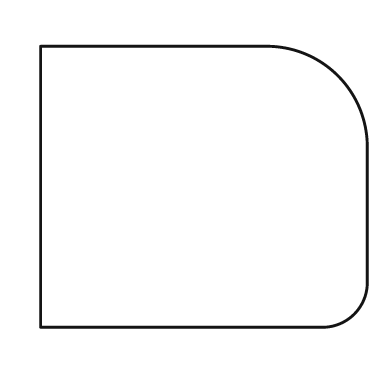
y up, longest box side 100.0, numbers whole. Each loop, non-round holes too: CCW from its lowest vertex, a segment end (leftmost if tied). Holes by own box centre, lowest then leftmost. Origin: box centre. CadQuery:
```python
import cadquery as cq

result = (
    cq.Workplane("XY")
    .moveTo(-50.0, -43.0)
    .lineTo(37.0, -43.0)
    .threePointArc((46.0, -39.0), (50.0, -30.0))
    .lineTo(50.0, 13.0)
    .threePointArc((41.0, 34.0), (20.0, 43.0))
    .lineTo(-50.0, 43.0)
    .close()
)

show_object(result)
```